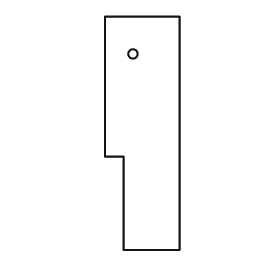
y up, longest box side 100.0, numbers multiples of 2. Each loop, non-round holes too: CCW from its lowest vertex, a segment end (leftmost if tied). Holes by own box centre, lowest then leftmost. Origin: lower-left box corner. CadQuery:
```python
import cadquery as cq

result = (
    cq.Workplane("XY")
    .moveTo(8.0, 0.0)
    .lineTo(32.0, 0.0)
    .lineTo(32.0, 100.0)
    .lineTo(0.0, 100.0)
    .lineTo(0.0, 40.0)
    .lineTo(8.0, 40.0)
    .close()
    .moveTo(12.0, 84.0)
    .circle(2.0)
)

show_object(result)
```